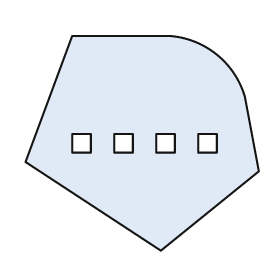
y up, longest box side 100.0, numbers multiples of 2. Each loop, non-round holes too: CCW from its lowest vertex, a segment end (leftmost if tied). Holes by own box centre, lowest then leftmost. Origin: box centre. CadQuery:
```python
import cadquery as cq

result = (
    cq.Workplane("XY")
    .moveTo(8.0, -46.0)
    .lineTo(50.0, -12.0)
    .lineTo(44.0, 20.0)
    .threePointArc((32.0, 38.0), (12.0, 46.0))
    .lineTo(-30.0, 46.0)
    .lineTo(-50.0, -8.0)
    .close()
    .moveTo(-30.0, -4.0)
    .lineTo(-22.0, -4.0)
    .lineTo(-22.0, 4.0)
    .lineTo(-30.0, 4.0)
    .close()
    .moveTo(-12.0, -4.0)
    .lineTo(-4.0, -4.0)
    .lineTo(-4.0, 4.0)
    .lineTo(-12.0, 4.0)
    .close()
    .moveTo(6.0, -4.0)
    .lineTo(14.0, -4.0)
    .lineTo(14.0, 4.0)
    .lineTo(6.0, 4.0)
    .close()
    .moveTo(24.0, -4.0)
    .lineTo(32.0, -4.0)
    .lineTo(32.0, 4.0)
    .lineTo(24.0, 4.0)
    .close()
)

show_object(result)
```